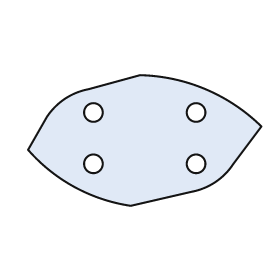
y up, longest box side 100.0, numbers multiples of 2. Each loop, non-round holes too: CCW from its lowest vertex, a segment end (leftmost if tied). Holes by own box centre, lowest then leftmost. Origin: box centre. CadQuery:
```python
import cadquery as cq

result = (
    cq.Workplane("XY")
    .moveTo(-6.0, -28.0)
    .lineTo(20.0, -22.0)
    .threePointArc((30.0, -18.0), (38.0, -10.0))
    .lineTo(50.0, 6.0)
    .threePointArc((26.0, 22.0), (-2.0, 28.0))
    .lineTo(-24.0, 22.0)
    .threePointArc((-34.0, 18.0), (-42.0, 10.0))
    .lineTo(-50.0, -4.0)
    .threePointArc((-30.0, -20.0), (-6.0, -28.0))
    .close()
    .moveTo(-22.0, -10.0)
    .circle(4.0)
    .moveTo(22.0, -10.0)
    .circle(4.0)
    .moveTo(-22.0, 12.0)
    .circle(4.0)
    .moveTo(22.0, 12.0)
    .circle(4.0)
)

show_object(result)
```